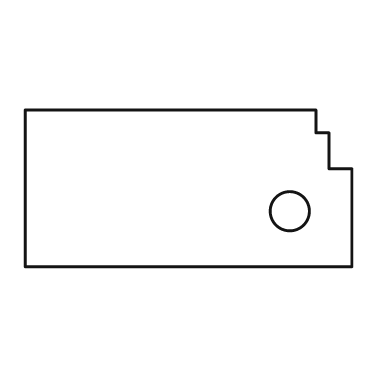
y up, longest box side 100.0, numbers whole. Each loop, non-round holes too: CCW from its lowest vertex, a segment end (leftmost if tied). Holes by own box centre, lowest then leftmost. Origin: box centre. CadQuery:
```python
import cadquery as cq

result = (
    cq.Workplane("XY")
    .moveTo(-50.0, -24.0)
    .lineTo(50.0, -24.0)
    .lineTo(50.0, 6.0)
    .lineTo(43.0, 6.0)
    .lineTo(43.0, 17.0)
    .lineTo(39.0, 17.0)
    .lineTo(39.0, 24.0)
    .lineTo(-50.0, 24.0)
    .close()
    .moveTo(31.0, -7.0)
    .circle(6.0)
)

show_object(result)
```